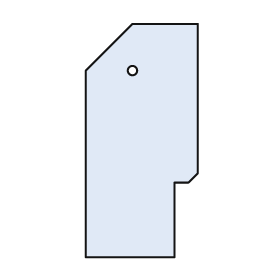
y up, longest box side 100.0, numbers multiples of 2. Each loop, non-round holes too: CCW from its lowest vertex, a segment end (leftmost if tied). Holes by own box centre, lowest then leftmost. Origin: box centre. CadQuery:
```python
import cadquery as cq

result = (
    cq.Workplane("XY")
    .moveTo(-24.0, -50.0)
    .lineTo(14.0, -50.0)
    .lineTo(14.0, -18.0)
    .lineTo(20.0, -18.0)
    .lineTo(24.0, -14.0)
    .lineTo(24.0, 50.0)
    .lineTo(-4.0, 50.0)
    .lineTo(-24.0, 30.0)
    .close()
    .moveTo(-4.0, 30.0)
    .circle(2.0)
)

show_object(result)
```